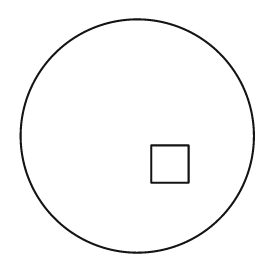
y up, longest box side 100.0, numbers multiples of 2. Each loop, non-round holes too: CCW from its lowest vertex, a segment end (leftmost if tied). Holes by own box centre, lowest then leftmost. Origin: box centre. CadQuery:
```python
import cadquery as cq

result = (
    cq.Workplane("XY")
    .moveTo(0.0, 0.0)
    .circle(50.0)
    .moveTo(6.0, -20.0)
    .lineTo(22.0, -20.0)
    .lineTo(22.0, -4.0)
    .lineTo(6.0, -4.0)
    .close()
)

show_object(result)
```